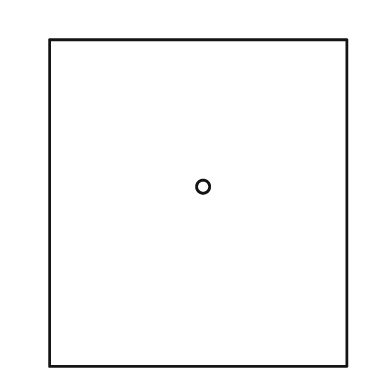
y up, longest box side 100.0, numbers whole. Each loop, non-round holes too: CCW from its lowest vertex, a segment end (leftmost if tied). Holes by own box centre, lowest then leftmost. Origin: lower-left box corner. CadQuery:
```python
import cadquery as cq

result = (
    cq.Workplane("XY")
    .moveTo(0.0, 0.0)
    .lineTo(91.0, 0.0)
    .lineTo(91.0, 100.0)
    .lineTo(0.0, 100.0)
    .close()
    .moveTo(47.0, 55.0)
    .circle(2.0)
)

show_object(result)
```